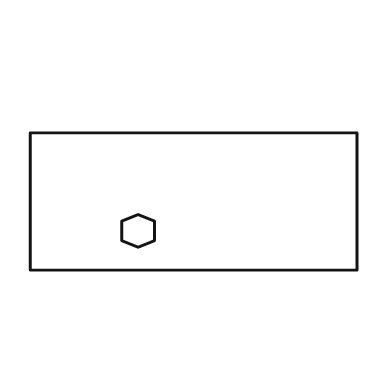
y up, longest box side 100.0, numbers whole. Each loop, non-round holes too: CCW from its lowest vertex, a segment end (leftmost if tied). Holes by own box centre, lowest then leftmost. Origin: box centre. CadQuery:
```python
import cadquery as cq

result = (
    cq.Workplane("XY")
    .moveTo(-50.0, -21.0)
    .lineTo(50.0, -21.0)
    .lineTo(50.0, 21.0)
    .lineTo(-50.0, 21.0)
    .close()
    .moveTo(-17.0, -14.0)
    .lineTo(-12.0, -12.0)
    .lineTo(-12.0, -6.0)
    .lineTo(-17.0, -4.0)
    .lineTo(-22.0, -6.0)
    .lineTo(-22.0, -12.0)
    .close()
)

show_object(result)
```